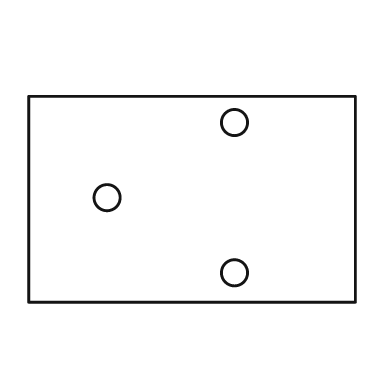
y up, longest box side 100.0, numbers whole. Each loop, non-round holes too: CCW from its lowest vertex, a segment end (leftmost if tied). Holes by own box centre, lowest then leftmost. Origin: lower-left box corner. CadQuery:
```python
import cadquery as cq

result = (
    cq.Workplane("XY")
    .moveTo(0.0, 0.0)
    .lineTo(100.0, 0.0)
    .lineTo(100.0, 63.0)
    .lineTo(0.0, 63.0)
    .close()
    .moveTo(63.0, 9.0)
    .circle(4.0)
    .moveTo(24.0, 32.0)
    .circle(4.0)
    .moveTo(63.0, 55.0)
    .circle(4.0)
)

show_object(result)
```